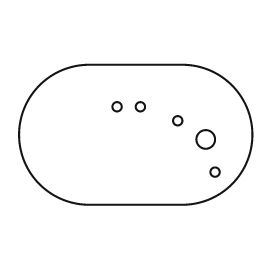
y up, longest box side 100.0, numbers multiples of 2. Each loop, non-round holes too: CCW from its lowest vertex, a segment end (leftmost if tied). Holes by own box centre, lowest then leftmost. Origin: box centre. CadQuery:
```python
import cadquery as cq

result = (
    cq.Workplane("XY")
    .moveTo(-20.0, -30.0)
    .lineTo(20.0, -30.0)
    .threePointArc((50.0, 0.0), (20.0, 30.0))
    .lineTo(-20.0, 30.0)
    .threePointArc((-50.0, 0.0), (-20.0, -30.0))
    .close()
    .moveTo(34.0, -16.0)
    .circle(2.0)
    .moveTo(30.0, -2.0)
    .circle(4.0)
    .moveTo(18.0, 6.0)
    .circle(2.0)
    .moveTo(-8.0, 12.0)
    .circle(2.0)
    .moveTo(2.0, 12.0)
    .circle(2.0)
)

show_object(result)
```